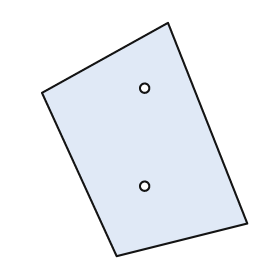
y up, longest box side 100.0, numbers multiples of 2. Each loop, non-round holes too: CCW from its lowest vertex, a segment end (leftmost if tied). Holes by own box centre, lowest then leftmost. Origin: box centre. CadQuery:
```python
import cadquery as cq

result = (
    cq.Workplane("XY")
    .moveTo(-12.0, -50.0)
    .lineTo(44.0, -36.0)
    .lineTo(10.0, 50.0)
    .lineTo(-44.0, 20.0)
    .close()
    .moveTo(0.0, -20.0)
    .circle(2.0)
    .moveTo(0.0, 22.0)
    .circle(2.0)
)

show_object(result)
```